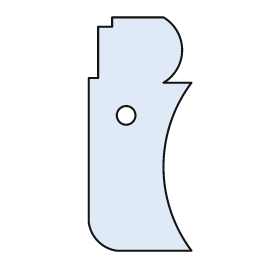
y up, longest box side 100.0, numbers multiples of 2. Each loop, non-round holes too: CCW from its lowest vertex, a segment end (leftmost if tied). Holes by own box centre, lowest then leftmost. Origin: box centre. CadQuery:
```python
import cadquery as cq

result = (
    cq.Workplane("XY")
    .moveTo(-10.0, -50.0)
    .lineTo(22.0, -50.0)
    .threePointArc((10.0, -14.0), (22.0, 22.0))
    .lineTo(10.0, 22.0)
    .threePointArc((18.0, 36.0), (10.0, 50.0))
    .lineTo(-12.0, 50.0)
    .lineTo(-12.0, 46.0)
    .lineTo(-18.0, 46.0)
    .lineTo(-18.0, 24.0)
    .lineTo(-22.0, 24.0)
    .lineTo(-22.0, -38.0)
    .threePointArc((-18.0, -46.0), (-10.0, -50.0))
    .close()
    .moveTo(-6.0, 8.0)
    .circle(4.0)
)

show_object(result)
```